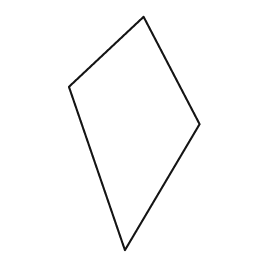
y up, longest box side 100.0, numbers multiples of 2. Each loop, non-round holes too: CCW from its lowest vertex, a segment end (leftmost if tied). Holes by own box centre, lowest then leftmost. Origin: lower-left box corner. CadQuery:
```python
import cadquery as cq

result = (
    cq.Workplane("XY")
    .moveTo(24.0, 0.0)
    .lineTo(56.0, 54.0)
    .lineTo(32.0, 100.0)
    .lineTo(0.0, 70.0)
    .close()
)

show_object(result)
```